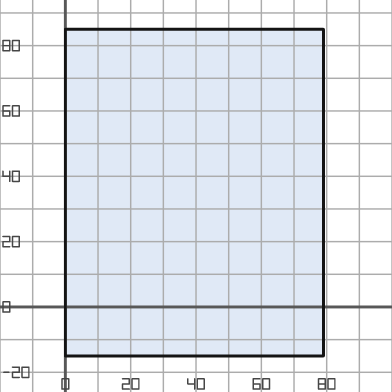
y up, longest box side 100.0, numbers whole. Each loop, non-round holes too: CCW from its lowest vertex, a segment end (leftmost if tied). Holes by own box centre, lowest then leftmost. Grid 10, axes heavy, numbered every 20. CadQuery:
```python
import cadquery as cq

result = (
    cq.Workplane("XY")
    .moveTo(0.0, -15.0)
    .lineTo(79.0, -15.0)
    .lineTo(79.0, 85.0)
    .lineTo(0.0, 85.0)
    .close()
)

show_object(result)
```